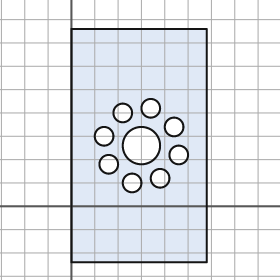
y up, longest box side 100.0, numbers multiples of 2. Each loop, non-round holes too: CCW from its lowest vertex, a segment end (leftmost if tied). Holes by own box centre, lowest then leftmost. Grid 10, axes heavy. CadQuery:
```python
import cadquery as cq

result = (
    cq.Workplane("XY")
    .moveTo(0.0, -24.0)
    .lineTo(58.0, -24.0)
    .lineTo(58.0, 76.0)
    .lineTo(0.0, 76.0)
    .close()
    .moveTo(26.0, 10.0)
    .circle(4.0)
    .moveTo(38.0, 12.0)
    .circle(4.0)
    .moveTo(16.0, 18.0)
    .circle(4.0)
    .moveTo(46.0, 22.0)
    .circle(4.0)
    .moveTo(30.0, 26.0)
    .circle(8.0)
    .moveTo(14.0, 30.0)
    .circle(4.0)
    .moveTo(44.0, 34.0)
    .circle(4.0)
    .moveTo(22.0, 40.0)
    .circle(4.0)
    .moveTo(34.0, 42.0)
    .circle(4.0)
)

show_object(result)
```